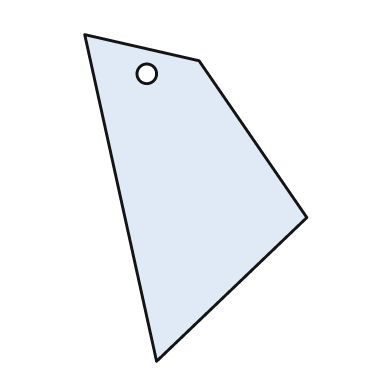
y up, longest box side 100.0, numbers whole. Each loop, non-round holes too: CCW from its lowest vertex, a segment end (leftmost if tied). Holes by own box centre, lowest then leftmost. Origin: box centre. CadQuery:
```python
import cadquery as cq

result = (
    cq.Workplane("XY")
    .moveTo(-12.0, -50.0)
    .lineTo(34.0, -6.0)
    .lineTo(1.0, 42.0)
    .lineTo(-34.0, 50.0)
    .close()
    .moveTo(-15.0, 38.0)
    .circle(3.0)
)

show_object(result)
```